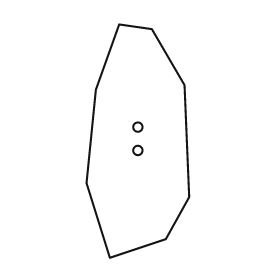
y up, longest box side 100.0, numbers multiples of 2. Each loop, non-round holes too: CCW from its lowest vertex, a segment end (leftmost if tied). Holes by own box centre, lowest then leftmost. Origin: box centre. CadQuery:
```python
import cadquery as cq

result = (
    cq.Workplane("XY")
    .moveTo(-12.0, -50.0)
    .lineTo(12.0, -42.0)
    .lineTo(22.0, -24.0)
    .lineTo(20.0, 24.0)
    .lineTo(6.0, 48.0)
    .lineTo(-8.0, 50.0)
    .lineTo(-18.0, 22.0)
    .lineTo(-22.0, -18.0)
    .close()
    .moveTo(0.0, -4.0)
    .circle(2.0)
    .moveTo(0.0, 6.0)
    .circle(2.0)
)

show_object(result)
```